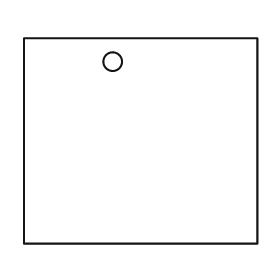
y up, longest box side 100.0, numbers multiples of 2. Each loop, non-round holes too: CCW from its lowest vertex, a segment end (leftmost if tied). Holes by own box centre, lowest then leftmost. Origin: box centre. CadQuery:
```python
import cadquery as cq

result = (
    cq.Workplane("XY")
    .moveTo(-50.0, -44.0)
    .lineTo(50.0, -44.0)
    .lineTo(50.0, 44.0)
    .lineTo(-50.0, 44.0)
    .close()
    .moveTo(-12.0, 34.0)
    .circle(4.0)
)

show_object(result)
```